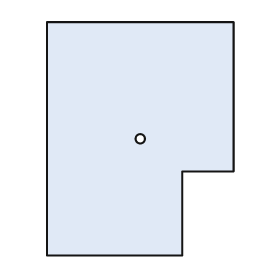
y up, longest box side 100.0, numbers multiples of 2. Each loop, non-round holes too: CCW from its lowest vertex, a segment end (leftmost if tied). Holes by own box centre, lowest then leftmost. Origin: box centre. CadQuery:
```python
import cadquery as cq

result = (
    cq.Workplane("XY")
    .moveTo(-40.0, -50.0)
    .lineTo(18.0, -50.0)
    .lineTo(18.0, -14.0)
    .lineTo(40.0, -14.0)
    .lineTo(40.0, 50.0)
    .lineTo(-40.0, 50.0)
    .close()
    .moveTo(0.0, 0.0)
    .circle(2.0)
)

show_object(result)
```